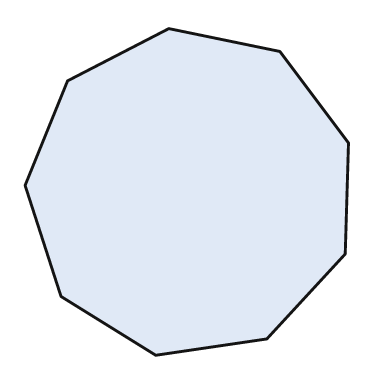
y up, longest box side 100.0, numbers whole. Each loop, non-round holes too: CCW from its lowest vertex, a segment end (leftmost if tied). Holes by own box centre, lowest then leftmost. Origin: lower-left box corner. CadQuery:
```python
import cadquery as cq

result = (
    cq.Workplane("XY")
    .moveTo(40.0, 0.0)
    .lineTo(74.0, 5.0)
    .lineTo(98.0, 31.0)
    .lineTo(99.0, 65.0)
    .lineTo(78.0, 93.0)
    .lineTo(44.0, 100.0)
    .lineTo(13.0, 84.0)
    .lineTo(0.0, 52.0)
    .lineTo(11.0, 18.0)
    .close()
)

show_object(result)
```